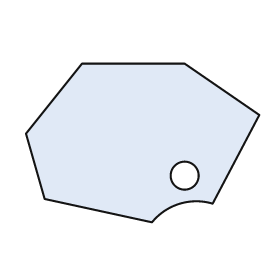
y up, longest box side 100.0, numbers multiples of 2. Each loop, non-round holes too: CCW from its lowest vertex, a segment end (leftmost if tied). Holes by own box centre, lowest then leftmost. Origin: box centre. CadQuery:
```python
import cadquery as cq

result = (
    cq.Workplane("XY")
    .moveTo(4.0, -34.0)
    .threePointArc((16.0, -26.0), (30.0, -26.0))
    .lineTo(50.0, 12.0)
    .lineTo(18.0, 34.0)
    .lineTo(-26.0, 34.0)
    .lineTo(-50.0, 4.0)
    .lineTo(-42.0, -24.0)
    .close()
    .moveTo(18.0, -14.0)
    .circle(6.0)
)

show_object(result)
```